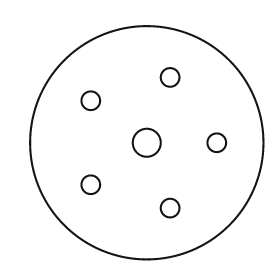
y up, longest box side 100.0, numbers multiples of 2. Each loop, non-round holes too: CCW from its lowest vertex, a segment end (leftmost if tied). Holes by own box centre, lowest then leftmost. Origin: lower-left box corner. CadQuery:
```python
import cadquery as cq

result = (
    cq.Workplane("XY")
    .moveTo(50.0, 50.0)
    .circle(50.0)
    .moveTo(60.0, 22.0)
    .circle(4.0)
    .moveTo(26.0, 32.0)
    .circle(4.0)
    .moveTo(50.0, 50.0)
    .circle(6.0)
    .moveTo(80.0, 50.0)
    .circle(4.0)
    .moveTo(26.0, 68.0)
    .circle(4.0)
    .moveTo(60.0, 78.0)
    .circle(4.0)
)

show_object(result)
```